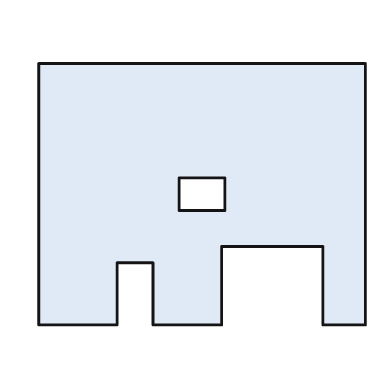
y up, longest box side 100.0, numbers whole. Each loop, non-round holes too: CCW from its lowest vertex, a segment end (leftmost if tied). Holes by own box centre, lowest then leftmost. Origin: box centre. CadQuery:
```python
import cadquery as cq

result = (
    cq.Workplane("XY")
    .moveTo(-50.0, -40.0)
    .lineTo(-26.0, -40.0)
    .lineTo(-26.0, -21.0)
    .lineTo(-15.0, -21.0)
    .lineTo(-15.0, -40.0)
    .lineTo(6.0, -40.0)
    .lineTo(6.0, -16.0)
    .lineTo(37.0, -16.0)
    .lineTo(37.0, -40.0)
    .lineTo(50.0, -40.0)
    .lineTo(50.0, 40.0)
    .lineTo(-50.0, 40.0)
    .close()
    .moveTo(-7.0, -5.0)
    .lineTo(7.0, -5.0)
    .lineTo(7.0, 5.0)
    .lineTo(-7.0, 5.0)
    .close()
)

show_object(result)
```